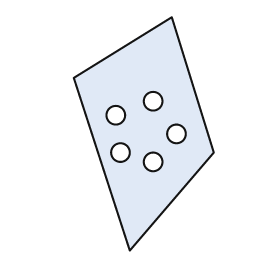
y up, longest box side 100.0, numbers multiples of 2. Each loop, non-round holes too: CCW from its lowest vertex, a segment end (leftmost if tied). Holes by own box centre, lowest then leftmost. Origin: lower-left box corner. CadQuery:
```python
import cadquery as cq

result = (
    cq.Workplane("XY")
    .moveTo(24.0, 0.0)
    .lineTo(60.0, 42.0)
    .lineTo(42.0, 100.0)
    .lineTo(0.0, 74.0)
    .close()
    .moveTo(34.0, 38.0)
    .circle(4.0)
    .moveTo(20.0, 42.0)
    .circle(4.0)
    .moveTo(44.0, 50.0)
    .circle(4.0)
    .moveTo(18.0, 58.0)
    .circle(4.0)
    .moveTo(34.0, 64.0)
    .circle(4.0)
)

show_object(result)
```